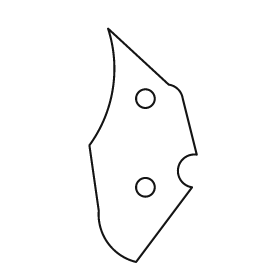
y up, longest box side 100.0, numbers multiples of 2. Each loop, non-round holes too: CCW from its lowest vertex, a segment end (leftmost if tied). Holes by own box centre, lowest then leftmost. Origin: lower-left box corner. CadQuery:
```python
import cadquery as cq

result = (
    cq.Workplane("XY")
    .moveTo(20.0, 0.0)
    .lineTo(44.0, 32.0)
    .threePointArc((38.0, 40.0), (46.0, 46.0))
    .lineTo(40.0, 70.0)
    .threePointArc((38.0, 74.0), (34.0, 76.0))
    .lineTo(8.0, 100.0)
    .threePointArc((10.0, 74.0), (0.0, 50.0))
    .lineTo(4.0, 22.0)
    .threePointArc((8.0, 8.0), (20.0, 0.0))
    .close()
    .moveTo(24.0, 32.0)
    .circle(4.0)
    .moveTo(24.0, 70.0)
    .circle(4.0)
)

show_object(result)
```